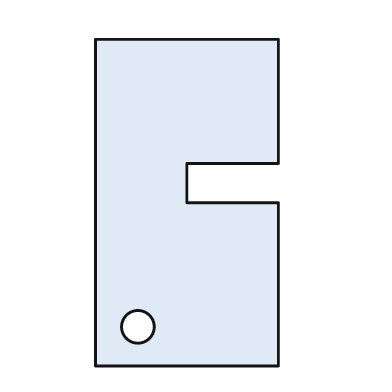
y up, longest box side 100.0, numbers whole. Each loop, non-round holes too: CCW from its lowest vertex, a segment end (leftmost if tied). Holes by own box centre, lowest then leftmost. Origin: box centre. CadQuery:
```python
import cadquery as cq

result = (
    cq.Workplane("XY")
    .moveTo(-28.0, -50.0)
    .lineTo(28.0, -50.0)
    .lineTo(28.0, 0.0)
    .lineTo(0.0, 0.0)
    .lineTo(0.0, 12.0)
    .lineTo(28.0, 12.0)
    .lineTo(28.0, 50.0)
    .lineTo(-28.0, 50.0)
    .close()
    .moveTo(-15.0, -38.0)
    .circle(5.0)
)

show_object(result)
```